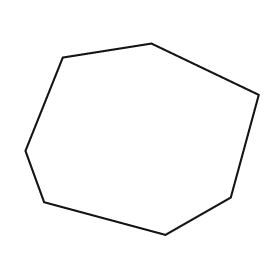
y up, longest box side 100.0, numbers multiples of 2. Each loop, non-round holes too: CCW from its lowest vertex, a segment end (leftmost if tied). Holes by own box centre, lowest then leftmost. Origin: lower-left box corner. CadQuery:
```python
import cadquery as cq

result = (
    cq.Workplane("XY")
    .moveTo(60.0, 0.0)
    .lineTo(88.0, 16.0)
    .lineTo(100.0, 60.0)
    .lineTo(54.0, 82.0)
    .lineTo(16.0, 76.0)
    .lineTo(0.0, 36.0)
    .lineTo(8.0, 14.0)
    .close()
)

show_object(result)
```